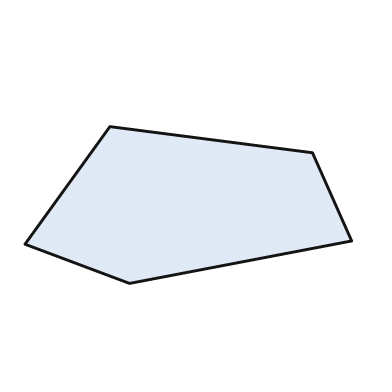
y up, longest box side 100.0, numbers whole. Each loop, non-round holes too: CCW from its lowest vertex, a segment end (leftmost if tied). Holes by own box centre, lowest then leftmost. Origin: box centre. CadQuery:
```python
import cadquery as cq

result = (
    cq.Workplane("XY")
    .moveTo(-18.0, -24.0)
    .lineTo(50.0, -11.0)
    .lineTo(38.0, 16.0)
    .lineTo(-24.0, 24.0)
    .lineTo(-50.0, -12.0)
    .close()
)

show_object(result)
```